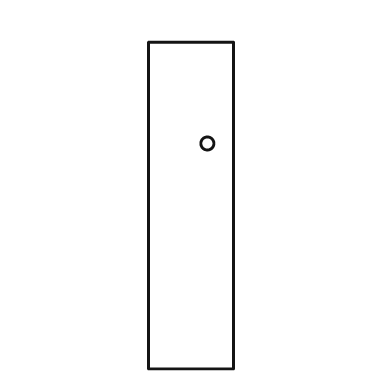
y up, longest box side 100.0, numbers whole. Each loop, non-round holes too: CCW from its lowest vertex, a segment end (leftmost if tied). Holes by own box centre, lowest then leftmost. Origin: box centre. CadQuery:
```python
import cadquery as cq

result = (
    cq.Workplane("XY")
    .moveTo(-13.0, -50.0)
    .lineTo(13.0, -50.0)
    .lineTo(13.0, 50.0)
    .lineTo(-13.0, 50.0)
    .close()
    .moveTo(5.0, 19.0)
    .circle(2.0)
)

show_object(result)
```